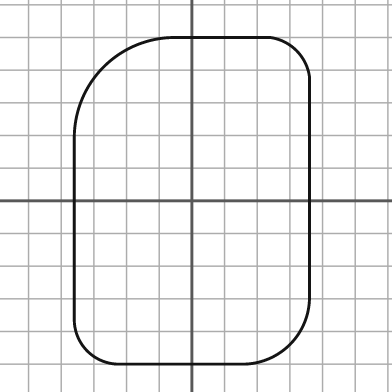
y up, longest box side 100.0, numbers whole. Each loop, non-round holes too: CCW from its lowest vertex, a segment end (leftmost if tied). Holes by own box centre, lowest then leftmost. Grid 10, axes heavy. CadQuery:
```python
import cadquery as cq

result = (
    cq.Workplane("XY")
    .moveTo(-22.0, -50.0)
    .lineTo(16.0, -50.0)
    .threePointArc((30.0, -44.0), (36.0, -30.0))
    .lineTo(36.0, 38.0)
    .threePointArc((32.0, 46.0), (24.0, 50.0))
    .lineTo(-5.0, 50.0)
    .threePointArc((-27.0, 41.0), (-36.0, 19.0))
    .lineTo(-36.0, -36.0)
    .threePointArc((-32.0, -46.0), (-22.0, -50.0))
    .close()
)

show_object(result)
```